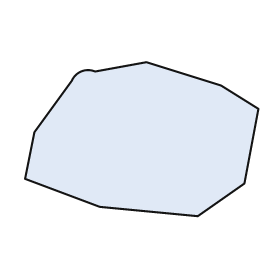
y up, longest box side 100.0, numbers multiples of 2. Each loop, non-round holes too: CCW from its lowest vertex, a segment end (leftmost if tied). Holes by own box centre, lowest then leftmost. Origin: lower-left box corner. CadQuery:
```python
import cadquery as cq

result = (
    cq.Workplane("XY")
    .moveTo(74.0, 0.0)
    .lineTo(94.0, 14.0)
    .lineTo(100.0, 46.0)
    .lineTo(84.0, 56.0)
    .lineTo(52.0, 66.0)
    .lineTo(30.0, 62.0)
    .threePointArc((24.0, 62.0), (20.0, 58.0))
    .lineTo(4.0, 36.0)
    .lineTo(0.0, 16.0)
    .lineTo(32.0, 4.0)
    .close()
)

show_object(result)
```